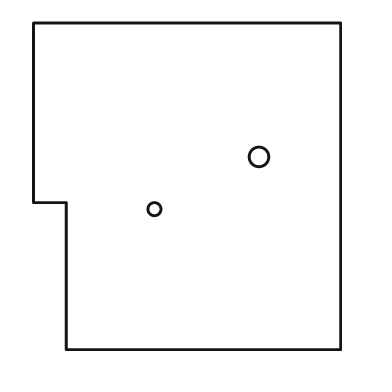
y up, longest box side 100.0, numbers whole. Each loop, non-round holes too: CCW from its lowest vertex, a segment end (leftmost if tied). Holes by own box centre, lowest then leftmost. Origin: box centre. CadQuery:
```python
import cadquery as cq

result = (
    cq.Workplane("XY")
    .moveTo(-37.0, -50.0)
    .lineTo(47.0, -50.0)
    .lineTo(47.0, 50.0)
    .lineTo(-47.0, 50.0)
    .lineTo(-47.0, -5.0)
    .lineTo(-37.0, -5.0)
    .close()
    .moveTo(-10.0, -7.0)
    .circle(2.0)
    .moveTo(22.0, 9.0)
    .circle(3.0)
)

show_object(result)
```